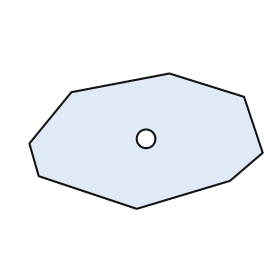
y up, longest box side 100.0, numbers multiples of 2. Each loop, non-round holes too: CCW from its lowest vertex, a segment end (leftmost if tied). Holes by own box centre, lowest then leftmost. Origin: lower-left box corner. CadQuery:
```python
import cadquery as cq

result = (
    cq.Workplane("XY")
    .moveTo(46.0, 0.0)
    .lineTo(86.0, 12.0)
    .lineTo(100.0, 24.0)
    .lineTo(92.0, 48.0)
    .lineTo(60.0, 58.0)
    .lineTo(18.0, 50.0)
    .lineTo(0.0, 28.0)
    .lineTo(4.0, 14.0)
    .close()
    .moveTo(50.0, 30.0)
    .circle(4.0)
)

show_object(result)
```